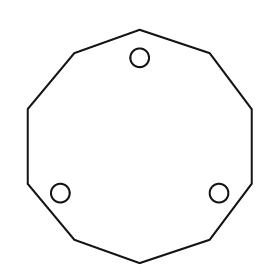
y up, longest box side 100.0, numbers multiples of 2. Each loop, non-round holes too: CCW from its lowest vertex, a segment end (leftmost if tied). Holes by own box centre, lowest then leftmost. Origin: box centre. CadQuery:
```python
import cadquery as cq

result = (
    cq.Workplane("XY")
    .moveTo(0.0, -50.0)
    .lineTo(30.0, -40.0)
    .lineTo(48.0, -16.0)
    .lineTo(48.0, 16.0)
    .lineTo(30.0, 40.0)
    .lineTo(0.0, 50.0)
    .lineTo(-28.0, 40.0)
    .lineTo(-48.0, 16.0)
    .lineTo(-48.0, -16.0)
    .lineTo(-28.0, -40.0)
    .close()
    .moveTo(-34.0, -20.0)
    .circle(4.0)
    .moveTo(34.0, -20.0)
    .circle(4.0)
    .moveTo(0.0, 38.0)
    .circle(4.0)
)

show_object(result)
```